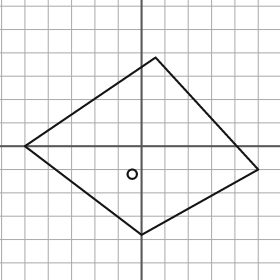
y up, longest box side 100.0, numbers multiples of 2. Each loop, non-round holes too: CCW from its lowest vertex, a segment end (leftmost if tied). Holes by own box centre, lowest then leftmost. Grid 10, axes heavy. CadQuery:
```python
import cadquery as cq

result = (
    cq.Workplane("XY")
    .moveTo(0.0, -38.0)
    .lineTo(50.0, -10.0)
    .lineTo(6.0, 38.0)
    .lineTo(-50.0, 0.0)
    .close()
    .moveTo(-4.0, -12.0)
    .circle(2.0)
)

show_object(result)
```